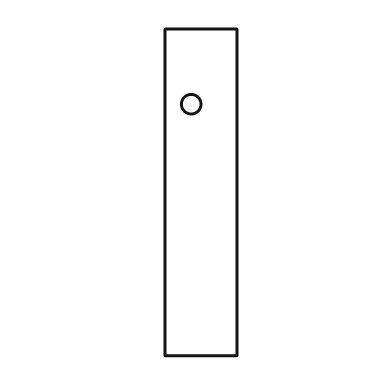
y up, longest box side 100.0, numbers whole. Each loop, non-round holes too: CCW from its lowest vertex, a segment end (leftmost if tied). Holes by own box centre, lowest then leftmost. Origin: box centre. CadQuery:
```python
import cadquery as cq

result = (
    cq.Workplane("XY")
    .moveTo(-11.0, -50.0)
    .lineTo(11.0, -50.0)
    .lineTo(11.0, 50.0)
    .lineTo(-11.0, 50.0)
    .close()
    .moveTo(-3.0, 27.0)
    .circle(3.0)
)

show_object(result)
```